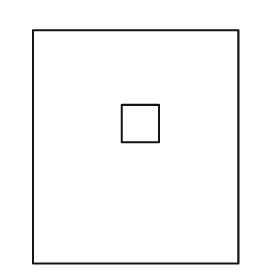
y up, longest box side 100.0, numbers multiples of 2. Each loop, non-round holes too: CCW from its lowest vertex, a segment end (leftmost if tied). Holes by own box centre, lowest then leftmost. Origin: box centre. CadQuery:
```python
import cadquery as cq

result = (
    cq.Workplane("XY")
    .moveTo(-44.0, -50.0)
    .lineTo(44.0, -50.0)
    .lineTo(44.0, 50.0)
    .lineTo(-44.0, 50.0)
    .close()
    .moveTo(-6.0, 2.0)
    .lineTo(10.0, 2.0)
    .lineTo(10.0, 18.0)
    .lineTo(-6.0, 18.0)
    .close()
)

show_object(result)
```